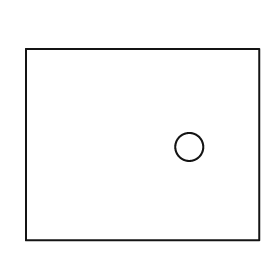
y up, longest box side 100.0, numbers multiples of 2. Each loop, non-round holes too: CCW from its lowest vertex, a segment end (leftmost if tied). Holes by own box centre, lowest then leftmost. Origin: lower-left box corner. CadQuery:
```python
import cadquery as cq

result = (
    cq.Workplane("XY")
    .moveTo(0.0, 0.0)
    .lineTo(100.0, 0.0)
    .lineTo(100.0, 82.0)
    .lineTo(0.0, 82.0)
    .close()
    .moveTo(70.0, 40.0)
    .circle(6.0)
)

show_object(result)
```